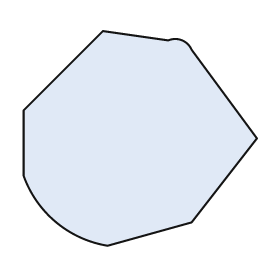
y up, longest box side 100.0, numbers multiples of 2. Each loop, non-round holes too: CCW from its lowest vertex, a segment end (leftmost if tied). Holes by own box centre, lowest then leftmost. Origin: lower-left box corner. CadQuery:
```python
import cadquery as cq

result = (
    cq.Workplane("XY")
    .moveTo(36.0, 0.0)
    .lineTo(72.0, 10.0)
    .lineTo(100.0, 46.0)
    .lineTo(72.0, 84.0)
    .threePointArc((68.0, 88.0), (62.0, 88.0))
    .lineTo(34.0, 92.0)
    .lineTo(0.0, 58.0)
    .lineTo(0.0, 30.0)
    .threePointArc((14.0, 10.0), (36.0, 0.0))
    .close()
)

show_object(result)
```